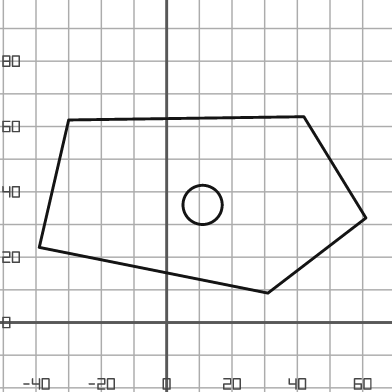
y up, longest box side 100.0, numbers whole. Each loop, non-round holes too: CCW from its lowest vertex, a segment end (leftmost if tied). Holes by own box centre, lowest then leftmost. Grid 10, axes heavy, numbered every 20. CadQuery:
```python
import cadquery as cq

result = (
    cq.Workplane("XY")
    .moveTo(31.0, 9.0)
    .lineTo(61.0, 32.0)
    .lineTo(42.0, 63.0)
    .lineTo(-30.0, 62.0)
    .lineTo(-39.0, 23.0)
    .close()
    .moveTo(11.0, 36.0)
    .circle(6.0)
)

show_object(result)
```